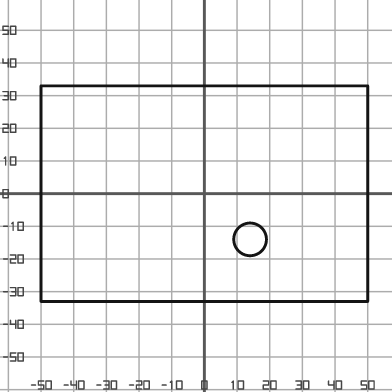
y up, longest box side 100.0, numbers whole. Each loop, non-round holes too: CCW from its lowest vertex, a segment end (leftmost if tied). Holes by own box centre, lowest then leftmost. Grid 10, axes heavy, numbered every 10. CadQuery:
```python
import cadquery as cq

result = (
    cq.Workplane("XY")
    .moveTo(-50.0, -33.0)
    .lineTo(50.0, -33.0)
    .lineTo(50.0, 33.0)
    .lineTo(-50.0, 33.0)
    .close()
    .moveTo(14.0, -14.0)
    .circle(5.0)
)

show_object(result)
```